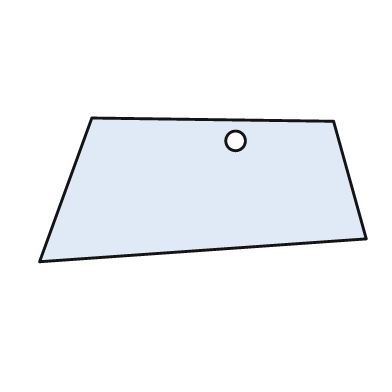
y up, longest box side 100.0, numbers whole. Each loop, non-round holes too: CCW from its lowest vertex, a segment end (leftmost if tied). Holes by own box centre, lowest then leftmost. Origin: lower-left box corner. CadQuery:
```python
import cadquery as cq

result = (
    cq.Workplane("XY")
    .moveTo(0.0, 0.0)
    .lineTo(100.0, 7.0)
    .lineTo(90.0, 43.0)
    .lineTo(16.0, 44.0)
    .close()
    .moveTo(60.0, 37.0)
    .circle(3.0)
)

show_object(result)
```